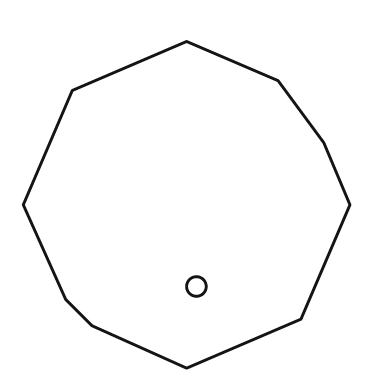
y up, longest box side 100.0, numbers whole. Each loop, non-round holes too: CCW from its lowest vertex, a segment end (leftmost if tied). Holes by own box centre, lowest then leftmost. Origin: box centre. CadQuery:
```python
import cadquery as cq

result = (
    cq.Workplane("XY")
    .moveTo(0.0, -50.0)
    .lineTo(35.0, -35.0)
    .lineTo(50.0, 0.0)
    .lineTo(42.0, 19.0)
    .lineTo(28.0, 38.0)
    .lineTo(0.0, 50.0)
    .lineTo(-35.0, 35.0)
    .lineTo(-50.0, 0.0)
    .lineTo(-37.0, -29.0)
    .lineTo(-29.0, -37.0)
    .close()
    .moveTo(3.0, -25.0)
    .circle(3.0)
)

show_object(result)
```